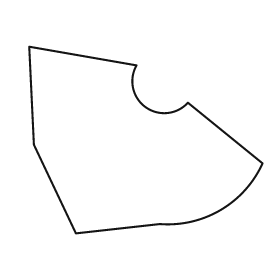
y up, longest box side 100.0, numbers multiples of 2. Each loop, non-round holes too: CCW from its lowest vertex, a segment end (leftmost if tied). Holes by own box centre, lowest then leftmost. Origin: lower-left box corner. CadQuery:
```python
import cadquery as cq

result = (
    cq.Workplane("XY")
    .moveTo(20.0, 0.0)
    .lineTo(56.0, 4.0)
    .threePointArc((82.0, 10.0), (100.0, 30.0))
    .lineTo(68.0, 56.0)
    .threePointArc((50.0, 54.0), (46.0, 72.0))
    .lineTo(0.0, 80.0)
    .lineTo(2.0, 38.0)
    .close()
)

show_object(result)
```